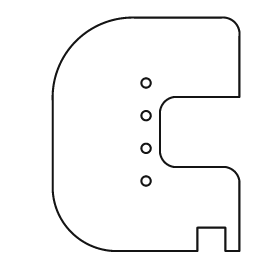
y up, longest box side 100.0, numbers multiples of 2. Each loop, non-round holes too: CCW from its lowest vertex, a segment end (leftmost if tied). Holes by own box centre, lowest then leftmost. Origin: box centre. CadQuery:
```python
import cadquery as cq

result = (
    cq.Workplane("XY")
    .moveTo(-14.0, -50.0)
    .lineTo(22.0, -50.0)
    .lineTo(22.0, -40.0)
    .lineTo(34.0, -40.0)
    .lineTo(34.0, -50.0)
    .lineTo(40.0, -50.0)
    .lineTo(40.0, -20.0)
    .threePointArc((38.0, -16.0), (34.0, -14.0))
    .lineTo(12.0, -14.0)
    .threePointArc((8.0, -12.0), (6.0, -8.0))
    .lineTo(6.0, 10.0)
    .threePointArc((8.0, 14.0), (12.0, 16.0))
    .lineTo(40.0, 16.0)
    .lineTo(40.0, 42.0)
    .threePointArc((38.0, 48.0), (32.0, 50.0))
    .lineTo(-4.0, 50.0)
    .threePointArc((-30.0, 40.0), (-40.0, 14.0))
    .lineTo(-40.0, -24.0)
    .threePointArc((-32.0, -42.0), (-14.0, -50.0))
    .close()
    .moveTo(0.0, -20.0)
    .circle(2.0)
    .moveTo(0.0, -6.0)
    .circle(2.0)
    .moveTo(0.0, 8.0)
    .circle(2.0)
    .moveTo(0.0, 22.0)
    .circle(2.0)
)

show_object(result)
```